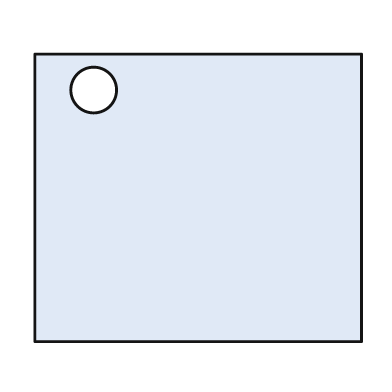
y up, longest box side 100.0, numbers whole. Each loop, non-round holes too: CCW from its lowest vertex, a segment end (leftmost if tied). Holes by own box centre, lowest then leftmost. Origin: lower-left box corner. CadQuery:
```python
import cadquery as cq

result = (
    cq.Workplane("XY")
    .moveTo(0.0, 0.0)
    .lineTo(100.0, 0.0)
    .lineTo(100.0, 88.0)
    .lineTo(0.0, 88.0)
    .close()
    .moveTo(18.0, 77.0)
    .circle(7.0)
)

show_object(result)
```